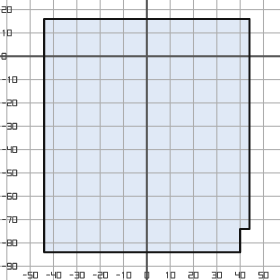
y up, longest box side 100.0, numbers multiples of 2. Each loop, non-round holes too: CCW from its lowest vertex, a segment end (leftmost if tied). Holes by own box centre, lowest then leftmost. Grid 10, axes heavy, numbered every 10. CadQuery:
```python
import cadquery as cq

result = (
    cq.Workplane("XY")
    .moveTo(-44.0, -84.0)
    .lineTo(40.0, -84.0)
    .lineTo(40.0, -74.0)
    .lineTo(44.0, -74.0)
    .lineTo(44.0, 16.0)
    .lineTo(-44.0, 16.0)
    .close()
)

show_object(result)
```